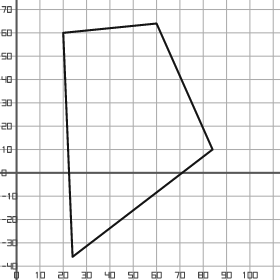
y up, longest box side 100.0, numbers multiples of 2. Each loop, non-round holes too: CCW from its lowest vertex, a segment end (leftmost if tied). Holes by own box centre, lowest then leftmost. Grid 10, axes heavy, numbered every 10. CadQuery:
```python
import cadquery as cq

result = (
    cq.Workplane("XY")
    .moveTo(24.0, -36.0)
    .lineTo(84.0, 10.0)
    .lineTo(60.0, 64.0)
    .lineTo(20.0, 60.0)
    .close()
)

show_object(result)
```